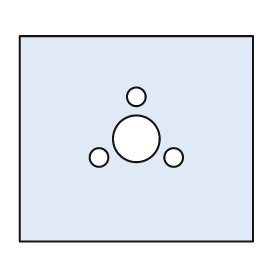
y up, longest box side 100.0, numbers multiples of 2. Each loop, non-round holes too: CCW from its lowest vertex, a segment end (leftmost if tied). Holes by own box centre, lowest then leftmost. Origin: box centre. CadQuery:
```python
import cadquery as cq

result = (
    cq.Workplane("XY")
    .moveTo(-50.0, -44.0)
    .lineTo(50.0, -44.0)
    .lineTo(50.0, 44.0)
    .lineTo(-50.0, 44.0)
    .close()
    .moveTo(-16.0, -8.0)
    .circle(4.0)
    .moveTo(16.0, -8.0)
    .circle(4.0)
    .moveTo(0.0, 0.0)
    .circle(10.0)
    .moveTo(0.0, 18.0)
    .circle(4.0)
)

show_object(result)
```